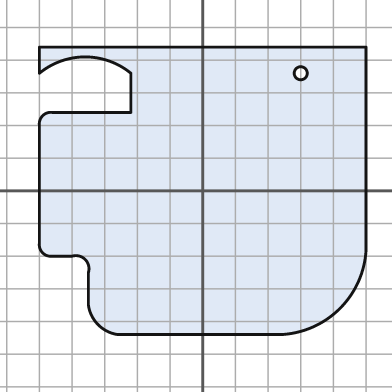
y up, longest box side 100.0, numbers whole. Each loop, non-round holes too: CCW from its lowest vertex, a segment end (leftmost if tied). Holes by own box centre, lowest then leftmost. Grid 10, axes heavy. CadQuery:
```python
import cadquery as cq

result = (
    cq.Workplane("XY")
    .moveTo(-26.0, -44.0)
    .lineTo(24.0, -44.0)
    .threePointArc((42.0, -36.0), (50.0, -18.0))
    .lineTo(50.0, 44.0)
    .lineTo(-50.0, 44.0)
    .lineTo(-50.0, 36.0)
    .threePointArc((-36.0, 41.0), (-22.0, 36.0))
    .lineTo(-22.0, 24.0)
    .lineTo(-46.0, 24.0)
    .threePointArc((-49.0, 23.0), (-50.0, 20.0))
    .lineTo(-50.0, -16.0)
    .threePointArc((-49.0, -19.0), (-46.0, -20.0))
    .lineTo(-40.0, -20.0)
    .threePointArc((-36.0, -21.0), (-35.0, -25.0))
    .lineTo(-35.0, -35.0)
    .threePointArc((-32.0, -41.0), (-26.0, -44.0))
    .close()
    .moveTo(30.0, 36.0)
    .circle(2.0)
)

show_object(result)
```